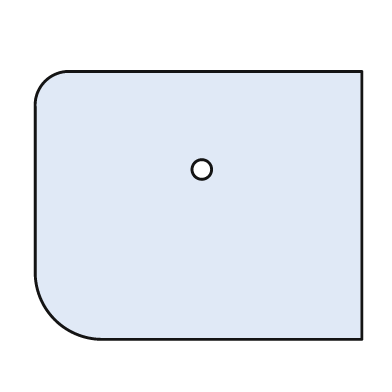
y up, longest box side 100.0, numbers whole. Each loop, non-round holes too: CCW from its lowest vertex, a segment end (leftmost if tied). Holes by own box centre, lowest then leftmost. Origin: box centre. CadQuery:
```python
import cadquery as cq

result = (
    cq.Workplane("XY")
    .moveTo(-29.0, -41.0)
    .lineTo(50.0, -41.0)
    .lineTo(50.0, 41.0)
    .lineTo(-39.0, 41.0)
    .threePointArc((-47.0, 38.0), (-50.0, 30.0))
    .lineTo(-50.0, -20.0)
    .threePointArc((-44.0, -35.0), (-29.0, -41.0))
    .close()
    .moveTo(1.0, 11.0)
    .circle(3.0)
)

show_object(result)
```